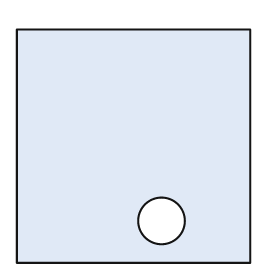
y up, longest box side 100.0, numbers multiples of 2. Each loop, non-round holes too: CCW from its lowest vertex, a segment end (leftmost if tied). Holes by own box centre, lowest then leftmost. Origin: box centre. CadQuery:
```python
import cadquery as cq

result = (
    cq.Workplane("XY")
    .moveTo(-50.0, -50.0)
    .lineTo(50.0, -50.0)
    .lineTo(50.0, 50.0)
    .lineTo(-50.0, 50.0)
    .close()
    .moveTo(12.0, -32.0)
    .circle(10.0)
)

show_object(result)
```